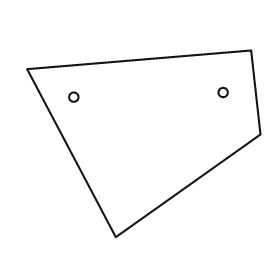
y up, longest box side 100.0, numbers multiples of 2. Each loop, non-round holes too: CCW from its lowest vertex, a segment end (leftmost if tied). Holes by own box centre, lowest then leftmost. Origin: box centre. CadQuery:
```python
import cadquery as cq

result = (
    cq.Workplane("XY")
    .moveTo(-12.0, -40.0)
    .lineTo(50.0, 4.0)
    .lineTo(46.0, 40.0)
    .lineTo(-50.0, 32.0)
    .close()
    .moveTo(-30.0, 20.0)
    .circle(2.0)
    .moveTo(34.0, 22.0)
    .circle(2.0)
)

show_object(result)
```